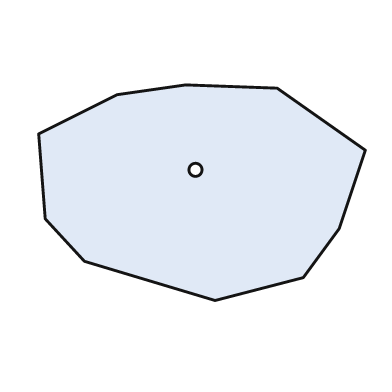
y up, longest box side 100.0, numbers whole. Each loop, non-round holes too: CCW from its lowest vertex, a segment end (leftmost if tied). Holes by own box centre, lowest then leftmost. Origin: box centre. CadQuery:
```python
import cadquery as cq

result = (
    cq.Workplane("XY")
    .moveTo(4.0, -33.0)
    .lineTo(31.0, -26.0)
    .lineTo(42.0, -11.0)
    .lineTo(50.0, 13.0)
    .lineTo(23.0, 32.0)
    .lineTo(-5.0, 33.0)
    .lineTo(-26.0, 30.0)
    .lineTo(-50.0, 18.0)
    .lineTo(-48.0, -8.0)
    .lineTo(-36.0, -21.0)
    .close()
    .moveTo(-2.0, 7.0)
    .circle(2.0)
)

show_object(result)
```